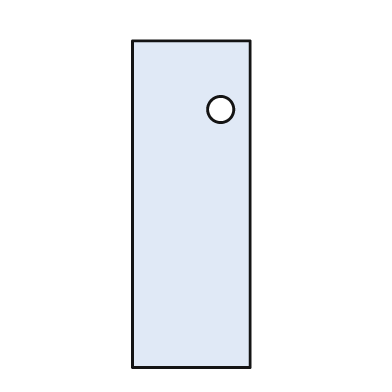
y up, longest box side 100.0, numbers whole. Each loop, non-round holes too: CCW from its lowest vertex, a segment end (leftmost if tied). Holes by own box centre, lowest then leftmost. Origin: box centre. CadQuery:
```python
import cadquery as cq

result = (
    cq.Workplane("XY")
    .moveTo(-18.0, -50.0)
    .lineTo(18.0, -50.0)
    .lineTo(18.0, 50.0)
    .lineTo(-18.0, 50.0)
    .close()
    .moveTo(9.0, 29.0)
    .circle(4.0)
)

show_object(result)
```